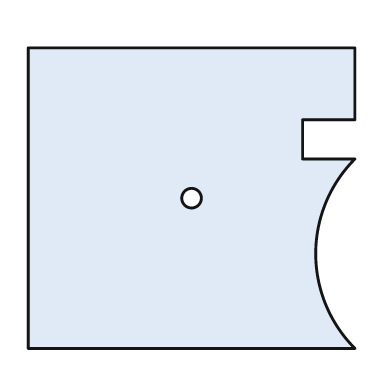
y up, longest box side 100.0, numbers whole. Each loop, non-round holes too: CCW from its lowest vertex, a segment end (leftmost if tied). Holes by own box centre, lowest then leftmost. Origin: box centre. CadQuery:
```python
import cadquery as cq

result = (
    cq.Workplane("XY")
    .moveTo(-50.0, -46.0)
    .lineTo(50.0, -46.0)
    .threePointArc((38.0, -17.0), (50.0, 12.0))
    .lineTo(34.0, 12.0)
    .lineTo(34.0, 24.0)
    .lineTo(50.0, 24.0)
    .lineTo(50.0, 46.0)
    .lineTo(-50.0, 46.0)
    .close()
    .moveTo(0.0, 0.0)
    .circle(3.0)
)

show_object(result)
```